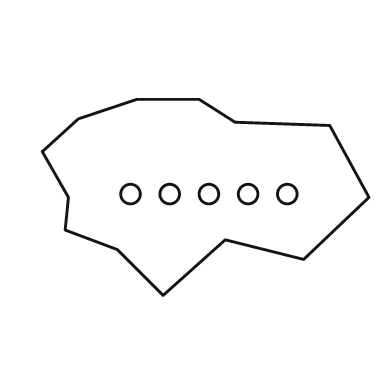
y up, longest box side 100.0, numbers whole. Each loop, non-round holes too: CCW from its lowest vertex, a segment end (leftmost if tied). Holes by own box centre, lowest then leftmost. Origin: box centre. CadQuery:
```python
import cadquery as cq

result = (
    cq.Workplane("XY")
    .moveTo(-13.0, -30.0)
    .lineTo(6.0, -13.0)
    .lineTo(30.0, -19.0)
    .lineTo(50.0, 0.0)
    .lineTo(38.0, 22.0)
    .lineTo(9.0, 23.0)
    .lineTo(-2.0, 30.0)
    .lineTo(-21.0, 30.0)
    .lineTo(-39.0, 24.0)
    .lineTo(-50.0, 14.0)
    .lineTo(-42.0, 0.0)
    .lineTo(-43.0, -10.0)
    .lineTo(-27.0, -16.0)
    .close()
    .moveTo(-23.0, 1.0)
    .circle(3.0)
    .moveTo(-11.0, 1.0)
    .circle(3.0)
    .moveTo(1.0, 1.0)
    .circle(3.0)
    .moveTo(13.0, 1.0)
    .circle(3.0)
    .moveTo(25.0, 1.0)
    .circle(3.0)
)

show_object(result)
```